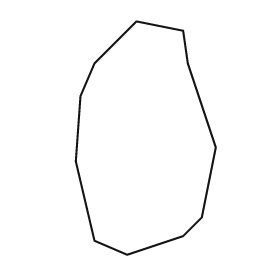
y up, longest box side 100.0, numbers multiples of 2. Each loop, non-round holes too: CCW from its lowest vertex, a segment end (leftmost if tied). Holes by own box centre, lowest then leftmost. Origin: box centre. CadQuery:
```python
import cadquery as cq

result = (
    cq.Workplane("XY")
    .moveTo(-8.0, -50.0)
    .lineTo(16.0, -42.0)
    .lineTo(24.0, -34.0)
    .lineTo(30.0, -4.0)
    .lineTo(18.0, 32.0)
    .lineTo(16.0, 46.0)
    .lineTo(-4.0, 50.0)
    .lineTo(-22.0, 32.0)
    .lineTo(-28.0, 18.0)
    .lineTo(-30.0, -10.0)
    .lineTo(-22.0, -44.0)
    .close()
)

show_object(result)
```